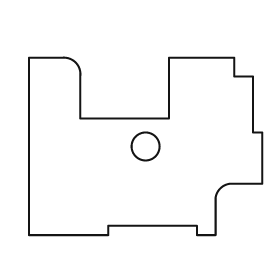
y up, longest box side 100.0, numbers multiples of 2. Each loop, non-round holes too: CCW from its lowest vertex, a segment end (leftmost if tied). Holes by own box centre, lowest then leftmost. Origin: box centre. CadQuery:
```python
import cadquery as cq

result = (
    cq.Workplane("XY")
    .moveTo(-50.0, -38.0)
    .lineTo(-16.0, -38.0)
    .lineTo(-16.0, -34.0)
    .lineTo(22.0, -34.0)
    .lineTo(22.0, -38.0)
    .lineTo(30.0, -38.0)
    .lineTo(30.0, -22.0)
    .threePointArc((32.0, -18.0), (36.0, -16.0))
    .lineTo(50.0, -16.0)
    .lineTo(50.0, 6.0)
    .lineTo(46.0, 6.0)
    .lineTo(46.0, 30.0)
    .lineTo(38.0, 30.0)
    .lineTo(38.0, 38.0)
    .lineTo(10.0, 38.0)
    .lineTo(10.0, 12.0)
    .lineTo(-28.0, 12.0)
    .lineTo(-28.0, 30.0)
    .threePointArc((-30.0, 36.0), (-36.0, 38.0))
    .lineTo(-50.0, 38.0)
    .close()
    .moveTo(0.0, 0.0)
    .circle(6.0)
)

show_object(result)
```